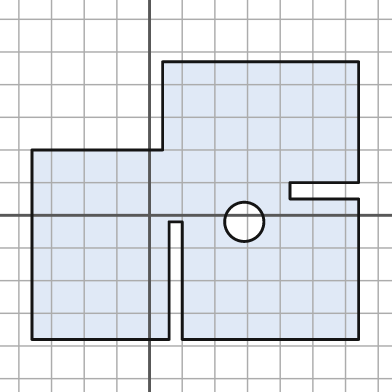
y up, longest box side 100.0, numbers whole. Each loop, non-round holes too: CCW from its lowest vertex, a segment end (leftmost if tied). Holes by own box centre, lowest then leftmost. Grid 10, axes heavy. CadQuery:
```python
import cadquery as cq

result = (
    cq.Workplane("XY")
    .moveTo(-36.0, -38.0)
    .lineTo(6.0, -38.0)
    .lineTo(6.0, -2.0)
    .lineTo(10.0, -2.0)
    .lineTo(10.0, -38.0)
    .lineTo(64.0, -38.0)
    .lineTo(64.0, 5.0)
    .lineTo(43.0, 5.0)
    .lineTo(43.0, 10.0)
    .lineTo(64.0, 10.0)
    .lineTo(64.0, 47.0)
    .lineTo(4.0, 47.0)
    .lineTo(4.0, 20.0)
    .lineTo(-36.0, 20.0)
    .close()
    .moveTo(29.0, -2.0)
    .circle(6.0)
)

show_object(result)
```